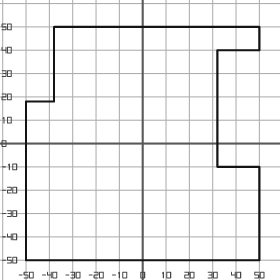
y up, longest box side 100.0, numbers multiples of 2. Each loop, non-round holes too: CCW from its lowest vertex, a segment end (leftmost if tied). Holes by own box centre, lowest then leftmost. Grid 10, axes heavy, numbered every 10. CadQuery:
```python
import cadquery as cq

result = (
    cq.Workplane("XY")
    .moveTo(-50.0, -50.0)
    .lineTo(50.0, -50.0)
    .lineTo(50.0, -10.0)
    .lineTo(32.0, -10.0)
    .lineTo(32.0, 40.0)
    .lineTo(50.0, 40.0)
    .lineTo(50.0, 50.0)
    .lineTo(-38.0, 50.0)
    .lineTo(-38.0, 18.0)
    .lineTo(-50.0, 18.0)
    .close()
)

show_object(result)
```